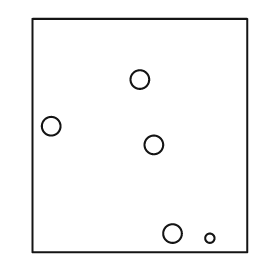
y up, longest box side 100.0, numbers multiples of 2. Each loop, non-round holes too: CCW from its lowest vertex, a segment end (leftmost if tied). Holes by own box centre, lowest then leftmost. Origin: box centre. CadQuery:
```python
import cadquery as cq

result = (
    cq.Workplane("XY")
    .moveTo(-46.0, -50.0)
    .lineTo(46.0, -50.0)
    .lineTo(46.0, 50.0)
    .lineTo(-46.0, 50.0)
    .close()
    .moveTo(30.0, -44.0)
    .circle(2.0)
    .moveTo(14.0, -42.0)
    .circle(4.0)
    .moveTo(6.0, -4.0)
    .circle(4.0)
    .moveTo(-38.0, 4.0)
    .circle(4.0)
    .moveTo(0.0, 24.0)
    .circle(4.0)
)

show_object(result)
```